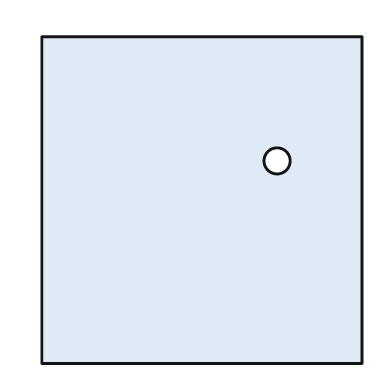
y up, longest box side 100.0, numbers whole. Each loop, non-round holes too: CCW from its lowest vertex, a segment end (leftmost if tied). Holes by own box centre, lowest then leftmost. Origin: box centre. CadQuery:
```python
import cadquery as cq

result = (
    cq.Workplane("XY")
    .moveTo(-49.0, -50.0)
    .lineTo(49.0, -50.0)
    .lineTo(49.0, 50.0)
    .lineTo(-49.0, 50.0)
    .close()
    .moveTo(23.0, 12.0)
    .circle(4.0)
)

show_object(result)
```